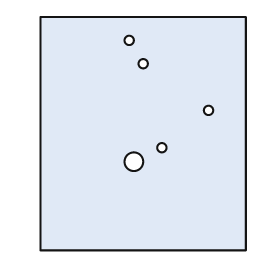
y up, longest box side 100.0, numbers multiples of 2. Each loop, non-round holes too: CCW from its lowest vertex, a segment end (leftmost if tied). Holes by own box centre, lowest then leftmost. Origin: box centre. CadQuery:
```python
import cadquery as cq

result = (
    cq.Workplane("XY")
    .moveTo(-44.0, -50.0)
    .lineTo(44.0, -50.0)
    .lineTo(44.0, 50.0)
    .lineTo(-44.0, 50.0)
    .close()
    .moveTo(-4.0, -12.0)
    .circle(4.0)
    .moveTo(8.0, -6.0)
    .circle(2.0)
    .moveTo(28.0, 10.0)
    .circle(2.0)
    .moveTo(0.0, 30.0)
    .circle(2.0)
    .moveTo(-6.0, 40.0)
    .circle(2.0)
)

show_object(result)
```